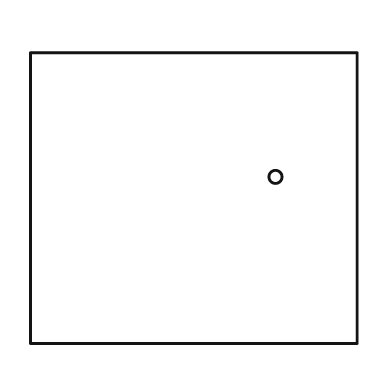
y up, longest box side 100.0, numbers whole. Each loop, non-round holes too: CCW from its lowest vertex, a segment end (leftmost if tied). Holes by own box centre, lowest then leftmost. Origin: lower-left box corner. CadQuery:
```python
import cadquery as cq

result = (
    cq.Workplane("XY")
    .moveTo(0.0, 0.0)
    .lineTo(100.0, 0.0)
    .lineTo(100.0, 89.0)
    .lineTo(0.0, 89.0)
    .close()
    .moveTo(75.0, 51.0)
    .circle(2.0)
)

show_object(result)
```